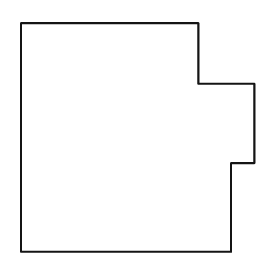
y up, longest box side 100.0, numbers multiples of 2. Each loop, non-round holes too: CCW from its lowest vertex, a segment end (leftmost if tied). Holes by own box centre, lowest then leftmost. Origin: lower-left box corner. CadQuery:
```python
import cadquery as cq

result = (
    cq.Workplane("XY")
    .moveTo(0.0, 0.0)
    .lineTo(90.0, 0.0)
    .lineTo(90.0, 38.0)
    .lineTo(100.0, 38.0)
    .lineTo(100.0, 72.0)
    .lineTo(76.0, 72.0)
    .lineTo(76.0, 98.0)
    .lineTo(0.0, 98.0)
    .close()
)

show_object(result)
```